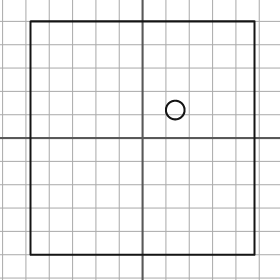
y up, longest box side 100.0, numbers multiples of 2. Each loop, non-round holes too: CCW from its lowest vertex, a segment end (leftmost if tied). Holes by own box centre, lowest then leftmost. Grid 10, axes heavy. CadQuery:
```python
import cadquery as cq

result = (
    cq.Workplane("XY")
    .moveTo(-48.0, -50.0)
    .lineTo(48.0, -50.0)
    .lineTo(48.0, 50.0)
    .lineTo(-48.0, 50.0)
    .close()
    .moveTo(14.0, 12.0)
    .circle(4.0)
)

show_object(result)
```